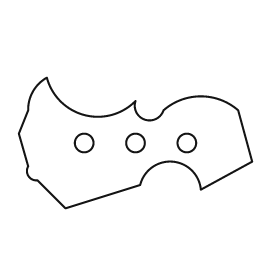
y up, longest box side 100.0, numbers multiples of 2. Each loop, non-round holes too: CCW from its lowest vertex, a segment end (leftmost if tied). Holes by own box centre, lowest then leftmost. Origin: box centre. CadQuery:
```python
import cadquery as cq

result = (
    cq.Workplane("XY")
    .moveTo(-30.0, -28.0)
    .lineTo(2.0, -18.0)
    .threePointArc((16.0, -8.0), (28.0, -20.0))
    .lineTo(50.0, -8.0)
    .lineTo(44.0, 14.0)
    .threePointArc((28.0, 20.0), (12.0, 14.0))
    .threePointArc((4.0, 10.0), (0.0, 18.0))
    .threePointArc((-22.0, 12.0), (-38.0, 28.0))
    .threePointArc((-44.0, 22.0), (-46.0, 14.0))
    .lineTo(-50.0, 4.0)
    .lineTo(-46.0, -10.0)
    .threePointArc((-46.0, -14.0), (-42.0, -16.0))
    .close()
    .moveTo(-22.0, 0.0)
    .circle(4.0)
    .moveTo(0.0, 0.0)
    .circle(4.0)
    .moveTo(22.0, 0.0)
    .circle(4.0)
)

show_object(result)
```